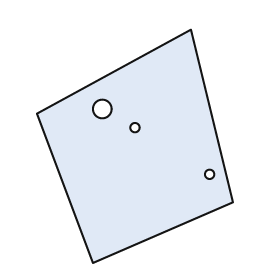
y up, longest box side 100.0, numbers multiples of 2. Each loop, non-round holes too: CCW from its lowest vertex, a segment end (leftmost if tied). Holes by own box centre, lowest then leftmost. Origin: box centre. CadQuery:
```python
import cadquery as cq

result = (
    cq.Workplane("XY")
    .moveTo(-18.0, -50.0)
    .lineTo(42.0, -24.0)
    .lineTo(24.0, 50.0)
    .lineTo(-42.0, 14.0)
    .close()
    .moveTo(32.0, -12.0)
    .circle(2.0)
    .moveTo(0.0, 8.0)
    .circle(2.0)
    .moveTo(-14.0, 16.0)
    .circle(4.0)
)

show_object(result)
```